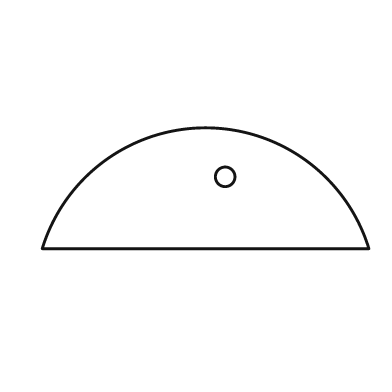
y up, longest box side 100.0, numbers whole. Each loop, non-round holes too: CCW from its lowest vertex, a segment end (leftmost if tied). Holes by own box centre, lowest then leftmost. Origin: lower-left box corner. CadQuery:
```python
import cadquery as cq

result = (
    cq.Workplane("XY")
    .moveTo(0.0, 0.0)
    .lineTo(100.0, 0.0)
    .threePointArc((50.0, 37.0), (0.0, 0.0))
    .close()
    .moveTo(56.0, 22.0)
    .circle(3.0)
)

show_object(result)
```